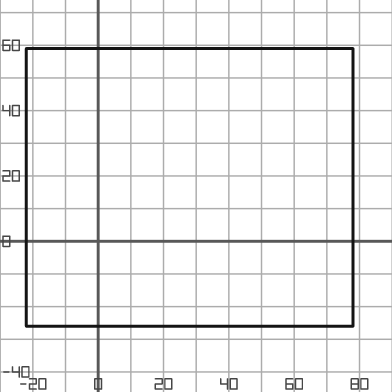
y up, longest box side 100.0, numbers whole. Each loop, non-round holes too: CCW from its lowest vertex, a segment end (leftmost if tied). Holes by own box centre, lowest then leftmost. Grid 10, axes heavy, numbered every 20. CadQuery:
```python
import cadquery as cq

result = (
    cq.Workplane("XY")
    .moveTo(-22.0, -26.0)
    .lineTo(78.0, -26.0)
    .lineTo(78.0, 59.0)
    .lineTo(-22.0, 59.0)
    .close()
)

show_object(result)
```